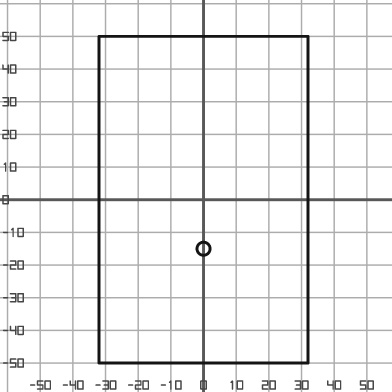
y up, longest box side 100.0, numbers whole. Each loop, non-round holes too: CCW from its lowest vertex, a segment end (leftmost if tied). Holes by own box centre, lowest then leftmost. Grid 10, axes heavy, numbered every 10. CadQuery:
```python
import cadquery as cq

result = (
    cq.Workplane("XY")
    .moveTo(-32.0, -50.0)
    .lineTo(32.0, -50.0)
    .lineTo(32.0, 50.0)
    .lineTo(-32.0, 50.0)
    .close()
    .moveTo(0.0, -15.0)
    .circle(2.0)
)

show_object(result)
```